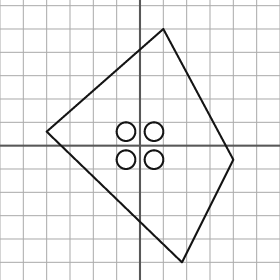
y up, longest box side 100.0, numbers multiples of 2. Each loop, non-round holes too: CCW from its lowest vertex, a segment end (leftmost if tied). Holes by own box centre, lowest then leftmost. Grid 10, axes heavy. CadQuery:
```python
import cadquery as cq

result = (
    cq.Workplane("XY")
    .moveTo(18.0, -50.0)
    .lineTo(40.0, -6.0)
    .lineTo(10.0, 50.0)
    .lineTo(-40.0, 6.0)
    .close()
    .moveTo(-6.0, -6.0)
    .circle(4.0)
    .moveTo(6.0, -6.0)
    .circle(4.0)
    .moveTo(-6.0, 6.0)
    .circle(4.0)
    .moveTo(6.0, 6.0)
    .circle(4.0)
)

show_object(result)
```